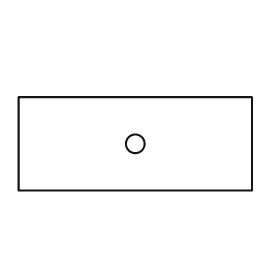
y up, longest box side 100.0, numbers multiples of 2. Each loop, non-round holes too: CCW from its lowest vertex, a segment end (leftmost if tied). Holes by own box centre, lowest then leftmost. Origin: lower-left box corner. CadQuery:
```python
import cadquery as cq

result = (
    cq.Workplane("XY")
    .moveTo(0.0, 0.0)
    .lineTo(100.0, 0.0)
    .lineTo(100.0, 40.0)
    .lineTo(0.0, 40.0)
    .close()
    .moveTo(50.0, 20.0)
    .circle(4.0)
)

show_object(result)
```